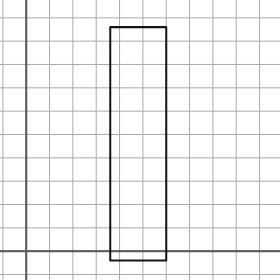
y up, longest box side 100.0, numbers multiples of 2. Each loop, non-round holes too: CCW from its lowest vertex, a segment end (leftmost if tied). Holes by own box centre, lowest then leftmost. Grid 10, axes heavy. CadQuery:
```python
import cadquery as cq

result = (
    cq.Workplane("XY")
    .moveTo(36.0, -4.0)
    .lineTo(60.0, -4.0)
    .lineTo(60.0, 96.0)
    .lineTo(36.0, 96.0)
    .close()
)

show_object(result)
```